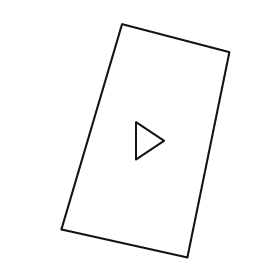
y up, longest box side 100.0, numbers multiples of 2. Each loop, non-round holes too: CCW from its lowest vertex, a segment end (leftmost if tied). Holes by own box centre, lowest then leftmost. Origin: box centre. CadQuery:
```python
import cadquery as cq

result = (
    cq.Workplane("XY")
    .moveTo(18.0, -50.0)
    .lineTo(36.0, 38.0)
    .lineTo(-10.0, 50.0)
    .lineTo(-36.0, -38.0)
    .close()
    .moveTo(-4.0, -8.0)
    .lineTo(8.0, 0.0)
    .lineTo(-4.0, 8.0)
    .close()
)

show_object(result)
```